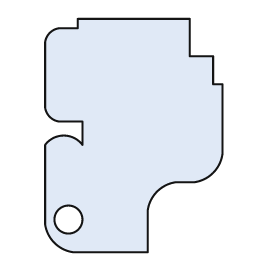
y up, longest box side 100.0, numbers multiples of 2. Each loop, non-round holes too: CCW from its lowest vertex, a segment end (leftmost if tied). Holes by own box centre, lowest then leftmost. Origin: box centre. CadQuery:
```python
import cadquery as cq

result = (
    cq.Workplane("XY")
    .moveTo(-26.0, -50.0)
    .lineTo(6.0, -50.0)
    .lineTo(6.0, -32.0)
    .threePointArc((10.0, -24.0), (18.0, -20.0))
    .lineTo(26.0, -20.0)
    .threePointArc((34.0, -16.0), (38.0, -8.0))
    .lineTo(38.0, 22.0)
    .lineTo(34.0, 22.0)
    .lineTo(34.0, 34.0)
    .lineTo(24.0, 34.0)
    .lineTo(24.0, 50.0)
    .lineTo(-24.0, 50.0)
    .lineTo(-24.0, 46.0)
    .lineTo(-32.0, 46.0)
    .threePointArc((-36.0, 44.0), (-38.0, 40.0))
    .lineTo(-38.0, 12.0)
    .threePointArc((-36.0, 8.0), (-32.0, 6.0))
    .lineTo(-22.0, 6.0)
    .lineTo(-22.0, -4.0)
    .threePointArc((-30.0, 0.0), (-38.0, -4.0))
    .lineTo(-38.0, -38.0)
    .threePointArc((-34.0, -46.0), (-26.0, -50.0))
    .close()
    .moveTo(-28.0, -36.0)
    .circle(6.0)
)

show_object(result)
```